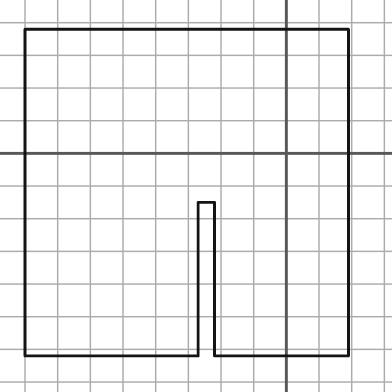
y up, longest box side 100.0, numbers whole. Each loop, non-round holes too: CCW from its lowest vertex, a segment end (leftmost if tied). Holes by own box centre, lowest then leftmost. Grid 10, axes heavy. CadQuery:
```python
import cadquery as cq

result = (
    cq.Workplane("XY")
    .moveTo(-80.0, -62.0)
    .lineTo(-27.0, -62.0)
    .lineTo(-27.0, -15.0)
    .lineTo(-22.0, -15.0)
    .lineTo(-22.0, -62.0)
    .lineTo(19.0, -62.0)
    .lineTo(19.0, 38.0)
    .lineTo(-80.0, 38.0)
    .close()
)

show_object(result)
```